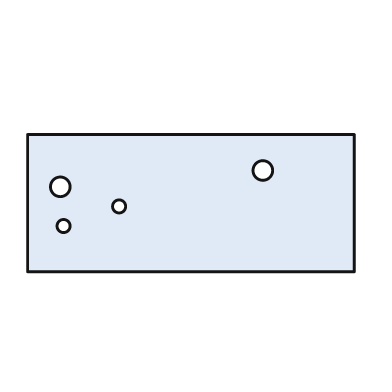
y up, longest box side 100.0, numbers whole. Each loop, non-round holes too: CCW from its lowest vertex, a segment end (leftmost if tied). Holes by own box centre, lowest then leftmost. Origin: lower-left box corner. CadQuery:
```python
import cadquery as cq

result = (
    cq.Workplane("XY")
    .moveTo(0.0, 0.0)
    .lineTo(100.0, 0.0)
    .lineTo(100.0, 42.0)
    .lineTo(0.0, 42.0)
    .close()
    .moveTo(11.0, 14.0)
    .circle(2.0)
    .moveTo(28.0, 20.0)
    .circle(2.0)
    .moveTo(10.0, 26.0)
    .circle(3.0)
    .moveTo(72.0, 31.0)
    .circle(3.0)
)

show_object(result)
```